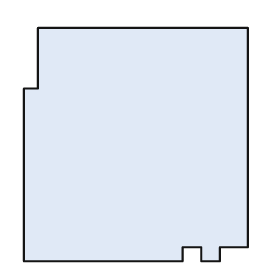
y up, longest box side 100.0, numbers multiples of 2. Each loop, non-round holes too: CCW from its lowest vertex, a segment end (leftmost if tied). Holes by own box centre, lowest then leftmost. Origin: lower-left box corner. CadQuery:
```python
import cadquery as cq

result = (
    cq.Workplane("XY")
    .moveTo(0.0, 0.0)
    .lineTo(68.0, 0.0)
    .lineTo(68.0, 6.0)
    .lineTo(76.0, 6.0)
    .lineTo(76.0, 0.0)
    .lineTo(84.0, 0.0)
    .lineTo(84.0, 6.0)
    .lineTo(96.0, 6.0)
    .lineTo(96.0, 100.0)
    .lineTo(6.0, 100.0)
    .lineTo(6.0, 74.0)
    .lineTo(0.0, 74.0)
    .close()
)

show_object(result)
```